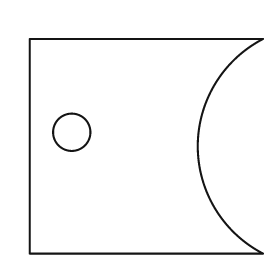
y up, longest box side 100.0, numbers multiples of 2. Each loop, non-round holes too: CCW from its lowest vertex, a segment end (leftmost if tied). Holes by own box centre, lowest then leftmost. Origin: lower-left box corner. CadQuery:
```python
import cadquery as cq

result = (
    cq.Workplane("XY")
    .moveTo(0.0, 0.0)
    .lineTo(100.0, 0.0)
    .threePointArc((72.0, 46.0), (100.0, 92.0))
    .lineTo(0.0, 92.0)
    .close()
    .moveTo(18.0, 52.0)
    .circle(8.0)
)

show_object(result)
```